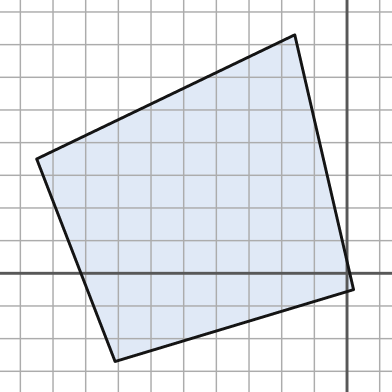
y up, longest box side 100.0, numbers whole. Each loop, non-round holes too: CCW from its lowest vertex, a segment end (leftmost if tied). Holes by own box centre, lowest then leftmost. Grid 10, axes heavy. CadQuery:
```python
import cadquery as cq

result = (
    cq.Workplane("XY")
    .moveTo(-71.0, -27.0)
    .lineTo(2.0, -5.0)
    .lineTo(-16.0, 73.0)
    .lineTo(-95.0, 35.0)
    .close()
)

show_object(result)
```